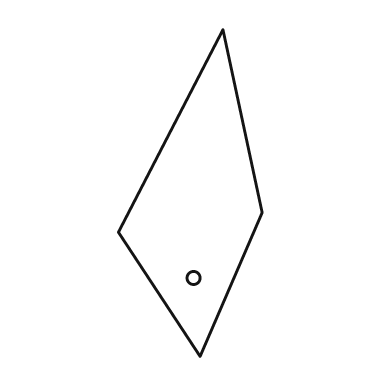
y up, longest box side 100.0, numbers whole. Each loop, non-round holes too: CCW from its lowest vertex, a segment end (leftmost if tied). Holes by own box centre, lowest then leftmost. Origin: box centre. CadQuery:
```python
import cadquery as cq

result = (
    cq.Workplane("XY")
    .moveTo(3.0, -50.0)
    .lineTo(22.0, -6.0)
    .lineTo(10.0, 50.0)
    .lineTo(-22.0, -12.0)
    .close()
    .moveTo(1.0, -26.0)
    .circle(2.0)
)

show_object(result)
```